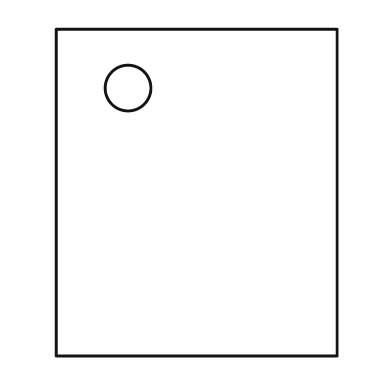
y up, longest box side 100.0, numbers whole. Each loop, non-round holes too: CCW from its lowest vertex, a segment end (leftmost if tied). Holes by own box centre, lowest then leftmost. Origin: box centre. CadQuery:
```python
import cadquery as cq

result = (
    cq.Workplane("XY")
    .moveTo(-43.0, -50.0)
    .lineTo(43.0, -50.0)
    .lineTo(43.0, 50.0)
    .lineTo(-43.0, 50.0)
    .close()
    .moveTo(-21.0, 32.0)
    .circle(7.0)
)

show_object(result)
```